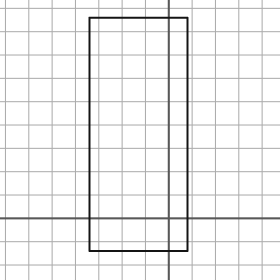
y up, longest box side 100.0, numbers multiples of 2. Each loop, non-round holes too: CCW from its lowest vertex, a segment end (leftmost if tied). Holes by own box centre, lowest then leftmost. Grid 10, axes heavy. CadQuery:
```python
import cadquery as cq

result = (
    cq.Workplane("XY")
    .moveTo(-34.0, -14.0)
    .lineTo(8.0, -14.0)
    .lineTo(8.0, 86.0)
    .lineTo(-34.0, 86.0)
    .close()
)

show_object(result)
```